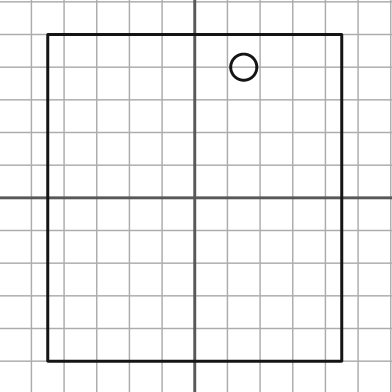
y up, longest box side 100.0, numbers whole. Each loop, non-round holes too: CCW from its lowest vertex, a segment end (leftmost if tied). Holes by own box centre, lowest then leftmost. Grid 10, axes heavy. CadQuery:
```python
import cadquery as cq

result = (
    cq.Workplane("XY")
    .moveTo(-45.0, -50.0)
    .lineTo(45.0, -50.0)
    .lineTo(45.0, 50.0)
    .lineTo(-45.0, 50.0)
    .close()
    .moveTo(15.0, 40.0)
    .circle(4.0)
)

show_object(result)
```